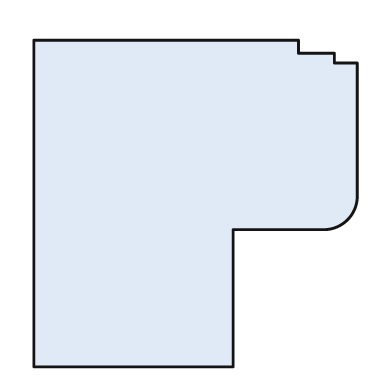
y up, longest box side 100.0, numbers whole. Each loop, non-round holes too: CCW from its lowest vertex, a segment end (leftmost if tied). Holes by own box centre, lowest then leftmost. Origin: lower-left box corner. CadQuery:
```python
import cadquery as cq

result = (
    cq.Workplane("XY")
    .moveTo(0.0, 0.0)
    .lineTo(61.0, 0.0)
    .lineTo(61.0, 42.0)
    .lineTo(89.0, 42.0)
    .threePointArc((96.0, 45.0), (99.0, 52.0))
    .lineTo(99.0, 93.0)
    .lineTo(92.0, 93.0)
    .lineTo(92.0, 96.0)
    .lineTo(81.0, 96.0)
    .lineTo(81.0, 100.0)
    .lineTo(0.0, 100.0)
    .close()
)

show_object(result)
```